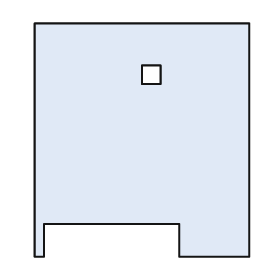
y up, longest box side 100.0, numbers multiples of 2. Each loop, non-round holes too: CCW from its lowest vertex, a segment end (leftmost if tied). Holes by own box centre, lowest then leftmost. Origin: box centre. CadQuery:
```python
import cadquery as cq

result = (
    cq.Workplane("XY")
    .moveTo(-46.0, -50.0)
    .lineTo(-42.0, -50.0)
    .lineTo(-42.0, -36.0)
    .lineTo(16.0, -36.0)
    .lineTo(16.0, -50.0)
    .lineTo(46.0, -50.0)
    .lineTo(46.0, 50.0)
    .lineTo(-46.0, 50.0)
    .close()
    .moveTo(0.0, 24.0)
    .lineTo(8.0, 24.0)
    .lineTo(8.0, 32.0)
    .lineTo(0.0, 32.0)
    .close()
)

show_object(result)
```